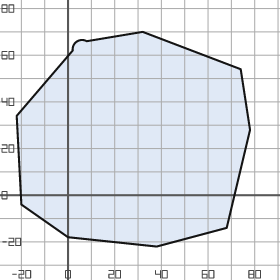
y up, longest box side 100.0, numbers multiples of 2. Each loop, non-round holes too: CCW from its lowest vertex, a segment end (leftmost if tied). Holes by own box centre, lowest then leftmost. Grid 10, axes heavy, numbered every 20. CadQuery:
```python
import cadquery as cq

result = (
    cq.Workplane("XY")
    .moveTo(38.0, -22.0)
    .lineTo(68.0, -14.0)
    .lineTo(78.0, 28.0)
    .lineTo(74.0, 54.0)
    .lineTo(32.0, 70.0)
    .lineTo(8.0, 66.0)
    .threePointArc((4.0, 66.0), (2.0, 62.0))
    .lineTo(-22.0, 34.0)
    .lineTo(-20.0, -4.0)
    .lineTo(0.0, -18.0)
    .close()
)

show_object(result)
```